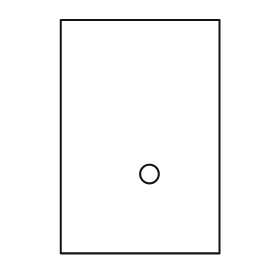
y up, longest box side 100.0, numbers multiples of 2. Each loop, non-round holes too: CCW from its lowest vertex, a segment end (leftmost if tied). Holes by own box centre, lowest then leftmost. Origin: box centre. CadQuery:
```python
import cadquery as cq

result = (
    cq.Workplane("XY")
    .moveTo(-34.0, -50.0)
    .lineTo(34.0, -50.0)
    .lineTo(34.0, 50.0)
    .lineTo(-34.0, 50.0)
    .close()
    .moveTo(4.0, -16.0)
    .circle(4.0)
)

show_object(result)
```